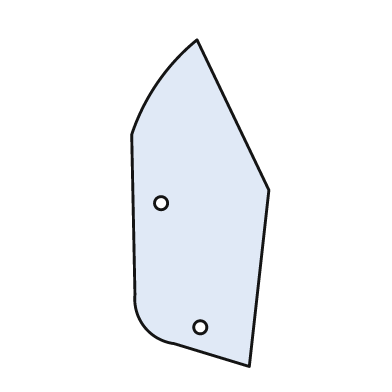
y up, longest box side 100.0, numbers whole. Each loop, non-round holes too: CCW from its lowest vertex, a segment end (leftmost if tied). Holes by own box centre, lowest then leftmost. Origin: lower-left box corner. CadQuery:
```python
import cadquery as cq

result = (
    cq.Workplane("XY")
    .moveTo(36.0, 0.0)
    .lineTo(42.0, 54.0)
    .lineTo(20.0, 100.0)
    .threePointArc((8.0, 87.0), (0.0, 71.0))
    .lineTo(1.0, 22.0)
    .threePointArc((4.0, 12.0), (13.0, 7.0))
    .close()
    .moveTo(21.0, 12.0)
    .circle(2.0)
    .moveTo(9.0, 50.0)
    .circle(2.0)
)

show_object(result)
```